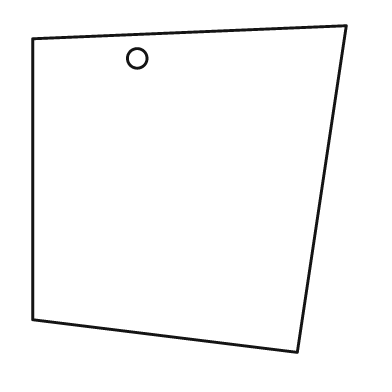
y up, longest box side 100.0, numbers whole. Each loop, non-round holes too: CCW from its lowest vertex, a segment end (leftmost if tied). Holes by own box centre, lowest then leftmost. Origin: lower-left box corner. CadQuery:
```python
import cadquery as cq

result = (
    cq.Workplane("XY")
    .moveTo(81.0, 0.0)
    .lineTo(96.0, 100.0)
    .lineTo(0.0, 96.0)
    .lineTo(0.0, 10.0)
    .close()
    .moveTo(32.0, 90.0)
    .circle(3.0)
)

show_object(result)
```